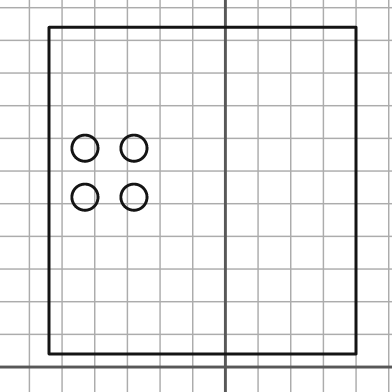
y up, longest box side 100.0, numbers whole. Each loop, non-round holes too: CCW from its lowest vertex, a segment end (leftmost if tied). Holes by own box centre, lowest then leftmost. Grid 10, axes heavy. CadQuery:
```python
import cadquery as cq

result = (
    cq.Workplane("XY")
    .moveTo(-54.0, 4.0)
    .lineTo(40.0, 4.0)
    .lineTo(40.0, 104.0)
    .lineTo(-54.0, 104.0)
    .close()
    .moveTo(-43.0, 52.0)
    .circle(4.0)
    .moveTo(-28.0, 52.0)
    .circle(4.0)
    .moveTo(-43.0, 67.0)
    .circle(4.0)
    .moveTo(-28.0, 67.0)
    .circle(4.0)
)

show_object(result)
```